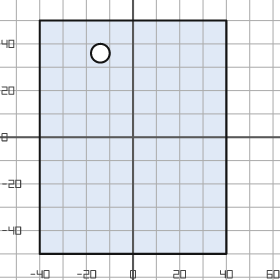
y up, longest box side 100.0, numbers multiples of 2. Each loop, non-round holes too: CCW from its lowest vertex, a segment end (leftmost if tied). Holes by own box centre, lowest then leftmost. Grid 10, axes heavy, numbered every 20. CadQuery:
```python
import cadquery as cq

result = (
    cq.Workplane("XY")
    .moveTo(-40.0, -50.0)
    .lineTo(40.0, -50.0)
    .lineTo(40.0, 50.0)
    .lineTo(-40.0, 50.0)
    .close()
    .moveTo(-14.0, 36.0)
    .circle(4.0)
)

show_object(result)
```